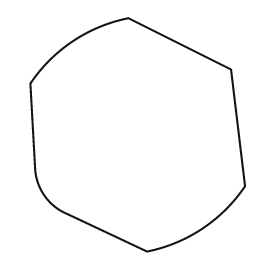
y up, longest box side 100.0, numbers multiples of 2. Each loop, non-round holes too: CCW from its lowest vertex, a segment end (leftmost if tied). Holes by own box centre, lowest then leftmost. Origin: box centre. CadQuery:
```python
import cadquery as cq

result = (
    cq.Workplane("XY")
    .moveTo(4.0, -50.0)
    .threePointArc((28.0, -40.0), (46.0, -22.0))
    .lineTo(40.0, 28.0)
    .lineTo(-4.0, 50.0)
    .threePointArc((-28.0, 40.0), (-46.0, 22.0))
    .lineTo(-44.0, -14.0)
    .threePointArc((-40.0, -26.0), (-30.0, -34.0))
    .close()
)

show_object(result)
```